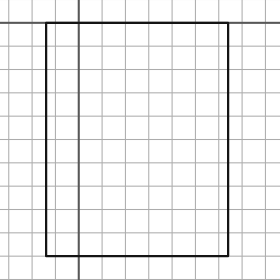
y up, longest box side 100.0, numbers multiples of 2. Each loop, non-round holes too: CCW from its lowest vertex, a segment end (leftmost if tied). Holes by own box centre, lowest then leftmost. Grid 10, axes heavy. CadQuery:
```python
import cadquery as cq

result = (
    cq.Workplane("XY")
    .moveTo(-14.0, -100.0)
    .lineTo(64.0, -100.0)
    .lineTo(64.0, 0.0)
    .lineTo(-14.0, 0.0)
    .close()
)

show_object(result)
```